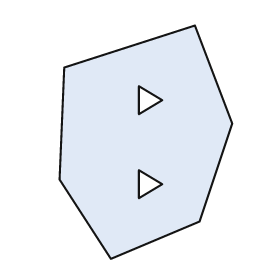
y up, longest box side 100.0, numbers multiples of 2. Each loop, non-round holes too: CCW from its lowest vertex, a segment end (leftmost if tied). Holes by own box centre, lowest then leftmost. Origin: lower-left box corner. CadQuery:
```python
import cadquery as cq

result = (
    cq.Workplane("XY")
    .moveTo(22.0, 0.0)
    .lineTo(60.0, 16.0)
    .lineTo(74.0, 58.0)
    .lineTo(58.0, 100.0)
    .lineTo(2.0, 82.0)
    .lineTo(0.0, 34.0)
    .close()
    .moveTo(34.0, 26.0)
    .lineTo(44.0, 32.0)
    .lineTo(34.0, 38.0)
    .close()
    .moveTo(34.0, 62.0)
    .lineTo(44.0, 68.0)
    .lineTo(34.0, 74.0)
    .close()
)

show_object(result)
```